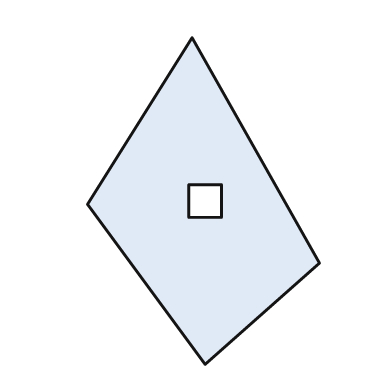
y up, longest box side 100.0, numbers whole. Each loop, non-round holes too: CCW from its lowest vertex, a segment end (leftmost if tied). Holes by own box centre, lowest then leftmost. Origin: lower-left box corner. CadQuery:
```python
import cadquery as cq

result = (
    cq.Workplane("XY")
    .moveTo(36.0, 0.0)
    .lineTo(71.0, 31.0)
    .lineTo(32.0, 100.0)
    .lineTo(0.0, 49.0)
    .close()
    .moveTo(31.0, 45.0)
    .lineTo(41.0, 45.0)
    .lineTo(41.0, 55.0)
    .lineTo(31.0, 55.0)
    .close()
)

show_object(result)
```